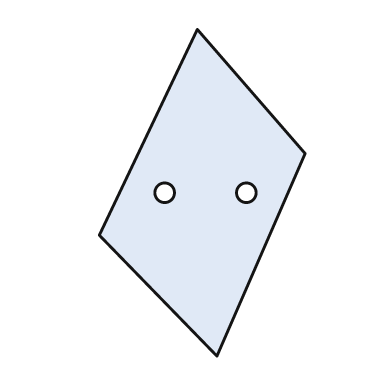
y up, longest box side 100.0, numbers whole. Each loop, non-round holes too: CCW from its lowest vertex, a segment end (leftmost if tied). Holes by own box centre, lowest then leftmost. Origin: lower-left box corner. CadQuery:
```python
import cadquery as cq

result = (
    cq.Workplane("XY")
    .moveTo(36.0, 0.0)
    .lineTo(63.0, 62.0)
    .lineTo(30.0, 100.0)
    .lineTo(0.0, 37.0)
    .close()
    .moveTo(20.0, 50.0)
    .circle(3.0)
    .moveTo(45.0, 50.0)
    .circle(3.0)
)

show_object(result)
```